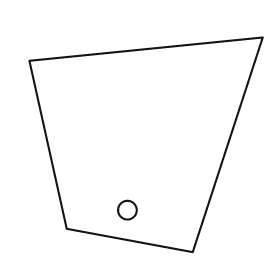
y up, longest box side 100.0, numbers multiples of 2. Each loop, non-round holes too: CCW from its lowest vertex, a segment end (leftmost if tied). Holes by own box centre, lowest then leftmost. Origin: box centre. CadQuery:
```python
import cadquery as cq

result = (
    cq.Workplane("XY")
    .moveTo(20.0, -46.0)
    .lineTo(50.0, 46.0)
    .lineTo(-50.0, 36.0)
    .lineTo(-34.0, -36.0)
    .close()
    .moveTo(-8.0, -28.0)
    .circle(4.0)
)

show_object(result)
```